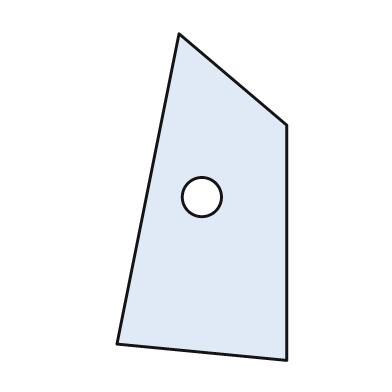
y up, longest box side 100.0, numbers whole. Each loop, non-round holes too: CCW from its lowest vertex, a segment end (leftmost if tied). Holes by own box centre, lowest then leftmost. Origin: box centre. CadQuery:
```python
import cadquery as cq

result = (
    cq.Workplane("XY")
    .moveTo(26.0, -50.0)
    .lineTo(26.0, 22.0)
    .lineTo(-7.0, 50.0)
    .lineTo(-26.0, -45.0)
    .close()
    .moveTo(0.0, 0.0)
    .circle(6.0)
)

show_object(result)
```